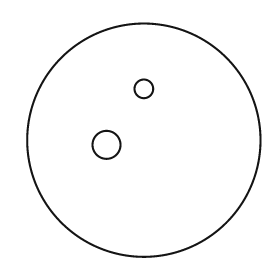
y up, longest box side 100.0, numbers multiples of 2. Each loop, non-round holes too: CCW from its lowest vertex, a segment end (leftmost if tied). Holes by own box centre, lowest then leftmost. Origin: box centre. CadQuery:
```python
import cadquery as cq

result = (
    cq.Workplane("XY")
    .moveTo(0.0, 0.0)
    .circle(50.0)
    .moveTo(-16.0, -2.0)
    .circle(6.0)
    .moveTo(0.0, 22.0)
    .circle(4.0)
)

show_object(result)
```